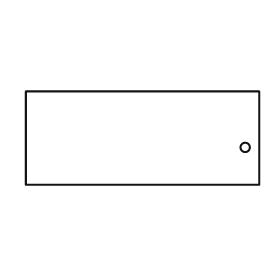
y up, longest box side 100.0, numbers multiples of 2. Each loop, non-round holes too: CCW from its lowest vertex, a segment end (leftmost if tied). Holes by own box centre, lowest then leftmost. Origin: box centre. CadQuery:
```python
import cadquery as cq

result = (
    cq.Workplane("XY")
    .moveTo(-50.0, -20.0)
    .lineTo(50.0, -20.0)
    .lineTo(50.0, 20.0)
    .lineTo(-50.0, 20.0)
    .close()
    .moveTo(44.0, -4.0)
    .circle(2.0)
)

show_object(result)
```